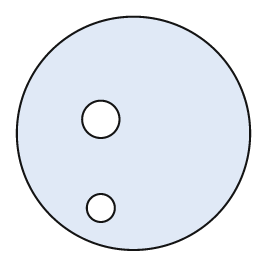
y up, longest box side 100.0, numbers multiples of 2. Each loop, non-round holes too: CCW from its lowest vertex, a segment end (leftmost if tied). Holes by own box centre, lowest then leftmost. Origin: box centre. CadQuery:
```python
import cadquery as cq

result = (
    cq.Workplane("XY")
    .moveTo(0.0, 0.0)
    .circle(50.0)
    .moveTo(-14.0, -32.0)
    .circle(6.0)
    .moveTo(-14.0, 6.0)
    .circle(8.0)
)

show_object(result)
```